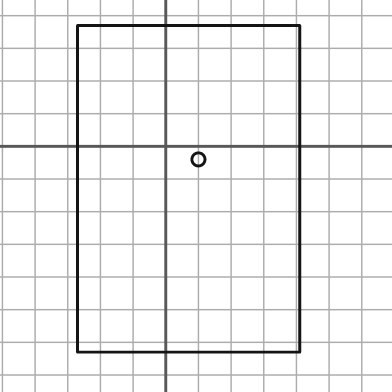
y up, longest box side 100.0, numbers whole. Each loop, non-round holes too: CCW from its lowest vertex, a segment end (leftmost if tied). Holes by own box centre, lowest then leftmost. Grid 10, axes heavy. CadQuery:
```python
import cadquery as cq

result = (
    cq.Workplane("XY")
    .moveTo(-27.0, -63.0)
    .lineTo(41.0, -63.0)
    .lineTo(41.0, 37.0)
    .lineTo(-27.0, 37.0)
    .close()
    .moveTo(10.0, -4.0)
    .circle(2.0)
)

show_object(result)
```